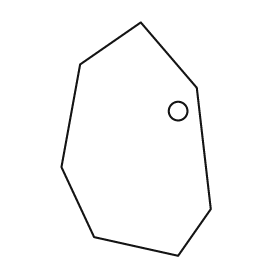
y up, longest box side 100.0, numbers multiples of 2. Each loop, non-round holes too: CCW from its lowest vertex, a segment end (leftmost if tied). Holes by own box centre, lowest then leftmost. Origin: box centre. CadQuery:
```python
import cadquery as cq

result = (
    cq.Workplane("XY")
    .moveTo(18.0, -50.0)
    .lineTo(32.0, -30.0)
    .lineTo(26.0, 22.0)
    .lineTo(2.0, 50.0)
    .lineTo(-24.0, 32.0)
    .lineTo(-32.0, -12.0)
    .lineTo(-18.0, -42.0)
    .close()
    .moveTo(18.0, 12.0)
    .circle(4.0)
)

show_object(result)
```